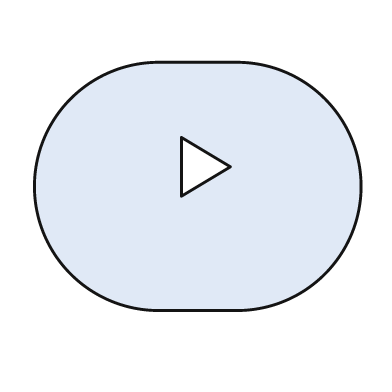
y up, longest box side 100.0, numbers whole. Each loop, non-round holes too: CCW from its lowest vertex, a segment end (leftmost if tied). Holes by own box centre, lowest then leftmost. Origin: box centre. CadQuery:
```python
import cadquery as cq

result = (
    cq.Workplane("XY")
    .moveTo(-12.0, -38.0)
    .lineTo(12.0, -38.0)
    .threePointArc((50.0, 0.0), (12.0, 38.0))
    .lineTo(-12.0, 38.0)
    .threePointArc((-50.0, 0.0), (-12.0, -38.0))
    .close()
    .moveTo(-5.0, -3.0)
    .lineTo(10.0, 6.0)
    .lineTo(-5.0, 15.0)
    .close()
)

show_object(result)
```